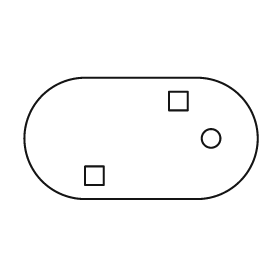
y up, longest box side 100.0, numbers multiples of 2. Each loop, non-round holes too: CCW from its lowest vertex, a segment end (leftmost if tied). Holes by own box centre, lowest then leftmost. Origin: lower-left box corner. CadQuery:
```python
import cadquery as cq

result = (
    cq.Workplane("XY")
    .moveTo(26.0, 0.0)
    .lineTo(74.0, 0.0)
    .threePointArc((100.0, 26.0), (74.0, 52.0))
    .lineTo(26.0, 52.0)
    .threePointArc((0.0, 26.0), (26.0, 0.0))
    .close()
    .moveTo(26.0, 6.0)
    .lineTo(34.0, 6.0)
    .lineTo(34.0, 14.0)
    .lineTo(26.0, 14.0)
    .close()
    .moveTo(80.0, 26.0)
    .circle(4.0)
    .moveTo(62.0, 38.0)
    .lineTo(70.0, 38.0)
    .lineTo(70.0, 46.0)
    .lineTo(62.0, 46.0)
    .close()
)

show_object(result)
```